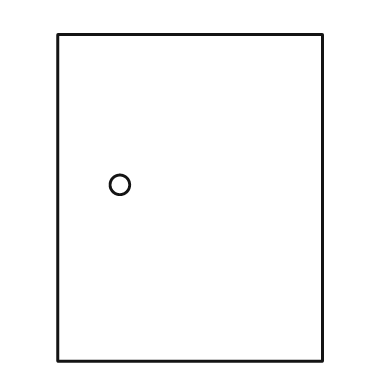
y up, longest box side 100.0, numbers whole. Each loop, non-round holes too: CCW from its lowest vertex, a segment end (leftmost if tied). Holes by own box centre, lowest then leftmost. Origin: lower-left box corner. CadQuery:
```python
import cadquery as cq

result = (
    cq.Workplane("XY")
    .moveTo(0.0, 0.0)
    .lineTo(81.0, 0.0)
    .lineTo(81.0, 100.0)
    .lineTo(0.0, 100.0)
    .close()
    .moveTo(19.0, 54.0)
    .circle(3.0)
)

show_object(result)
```